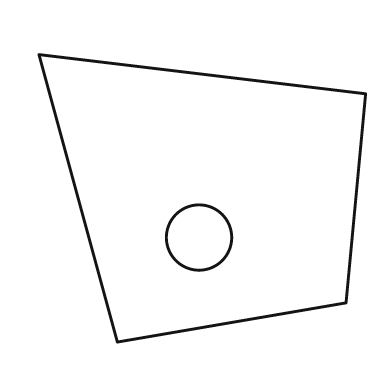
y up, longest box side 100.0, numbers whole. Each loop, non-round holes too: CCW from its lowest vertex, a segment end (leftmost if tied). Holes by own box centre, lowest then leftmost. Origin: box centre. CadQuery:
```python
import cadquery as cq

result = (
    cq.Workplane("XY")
    .moveTo(-26.0, -44.0)
    .lineTo(44.0, -32.0)
    .lineTo(50.0, 32.0)
    .lineTo(-50.0, 44.0)
    .close()
    .moveTo(-1.0, -12.0)
    .circle(10.0)
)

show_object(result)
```